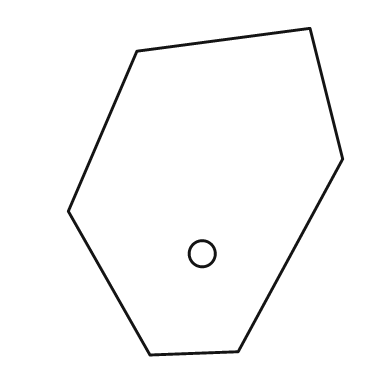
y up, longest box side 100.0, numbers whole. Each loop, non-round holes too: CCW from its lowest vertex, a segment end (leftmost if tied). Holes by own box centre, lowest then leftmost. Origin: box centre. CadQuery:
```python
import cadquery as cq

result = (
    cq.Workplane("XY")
    .moveTo(-17.0, -50.0)
    .lineTo(10.0, -49.0)
    .lineTo(42.0, 10.0)
    .lineTo(32.0, 50.0)
    .lineTo(-21.0, 43.0)
    .lineTo(-42.0, -6.0)
    .close()
    .moveTo(-1.0, -19.0)
    .circle(4.0)
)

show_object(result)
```